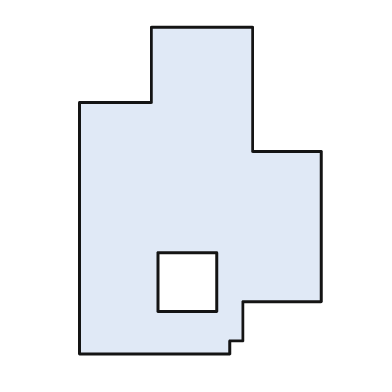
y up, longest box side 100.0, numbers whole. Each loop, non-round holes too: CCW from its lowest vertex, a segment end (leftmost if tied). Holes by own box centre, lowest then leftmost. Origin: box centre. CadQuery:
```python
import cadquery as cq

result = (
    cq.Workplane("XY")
    .moveTo(-37.0, -50.0)
    .lineTo(9.0, -50.0)
    .lineTo(9.0, -46.0)
    .lineTo(13.0, -46.0)
    .lineTo(13.0, -34.0)
    .lineTo(37.0, -34.0)
    .lineTo(37.0, 12.0)
    .lineTo(16.0, 12.0)
    .lineTo(16.0, 50.0)
    .lineTo(-15.0, 50.0)
    .lineTo(-15.0, 27.0)
    .lineTo(-37.0, 27.0)
    .close()
    .moveTo(-13.0, -37.0)
    .lineTo(5.0, -37.0)
    .lineTo(5.0, -19.0)
    .lineTo(-13.0, -19.0)
    .close()
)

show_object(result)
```